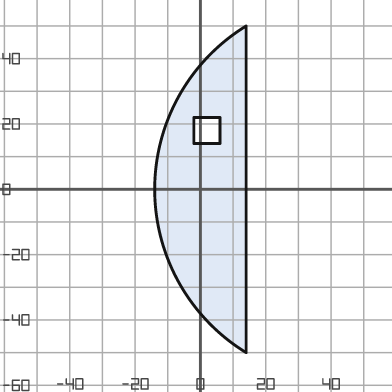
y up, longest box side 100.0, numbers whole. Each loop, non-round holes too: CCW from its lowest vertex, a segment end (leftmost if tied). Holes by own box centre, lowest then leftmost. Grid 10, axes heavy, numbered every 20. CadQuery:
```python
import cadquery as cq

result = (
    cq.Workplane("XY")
    .moveTo(14.0, -50.0)
    .lineTo(14.0, 50.0)
    .threePointArc((-14.0, 0.0), (14.0, -50.0))
    .close()
    .moveTo(-2.0, 14.0)
    .lineTo(6.0, 14.0)
    .lineTo(6.0, 22.0)
    .lineTo(-2.0, 22.0)
    .close()
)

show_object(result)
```